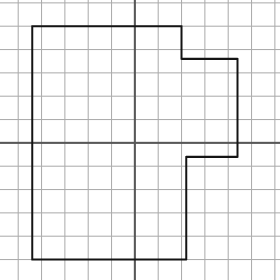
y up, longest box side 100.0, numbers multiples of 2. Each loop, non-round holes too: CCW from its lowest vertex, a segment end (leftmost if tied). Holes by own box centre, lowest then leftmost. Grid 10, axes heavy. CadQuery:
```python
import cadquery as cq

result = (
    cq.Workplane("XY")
    .moveTo(-44.0, -50.0)
    .lineTo(22.0, -50.0)
    .lineTo(22.0, -6.0)
    .lineTo(44.0, -6.0)
    .lineTo(44.0, 36.0)
    .lineTo(20.0, 36.0)
    .lineTo(20.0, 50.0)
    .lineTo(-44.0, 50.0)
    .close()
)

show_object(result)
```